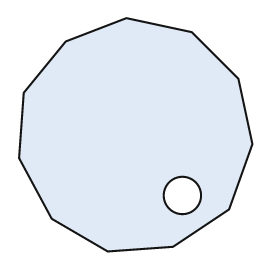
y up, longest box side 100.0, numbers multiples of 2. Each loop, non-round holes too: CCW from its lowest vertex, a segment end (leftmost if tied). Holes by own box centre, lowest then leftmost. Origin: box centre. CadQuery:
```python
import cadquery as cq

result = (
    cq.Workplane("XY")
    .moveTo(-12.0, -50.0)
    .lineTo(16.0, -48.0)
    .lineTo(40.0, -32.0)
    .lineTo(50.0, -4.0)
    .lineTo(44.0, 24.0)
    .lineTo(24.0, 44.0)
    .lineTo(-4.0, 50.0)
    .lineTo(-30.0, 40.0)
    .lineTo(-48.0, 18.0)
    .lineTo(-50.0, -10.0)
    .lineTo(-36.0, -36.0)
    .close()
    .moveTo(20.0, -26.0)
    .circle(8.0)
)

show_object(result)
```